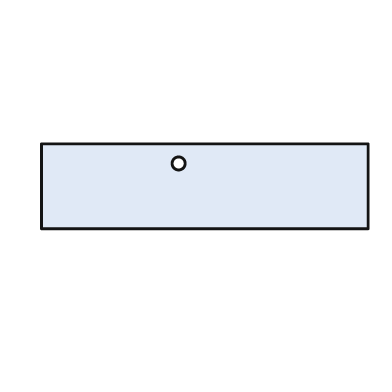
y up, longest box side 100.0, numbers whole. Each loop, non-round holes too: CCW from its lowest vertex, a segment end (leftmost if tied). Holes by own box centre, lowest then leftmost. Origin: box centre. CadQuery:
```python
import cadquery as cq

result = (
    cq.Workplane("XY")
    .moveTo(-50.0, -13.0)
    .lineTo(50.0, -13.0)
    .lineTo(50.0, 13.0)
    .lineTo(-50.0, 13.0)
    .close()
    .moveTo(-8.0, 7.0)
    .circle(2.0)
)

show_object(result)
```